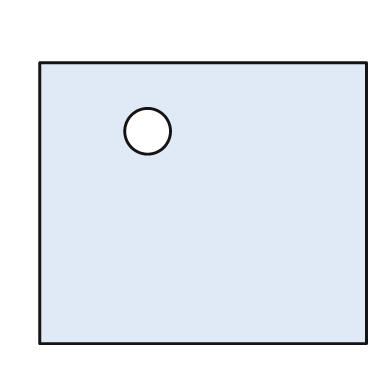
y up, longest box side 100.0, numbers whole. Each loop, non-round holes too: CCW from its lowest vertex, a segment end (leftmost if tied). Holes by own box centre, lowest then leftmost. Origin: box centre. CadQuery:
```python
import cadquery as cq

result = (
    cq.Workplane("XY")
    .moveTo(-50.0, -43.0)
    .lineTo(50.0, -43.0)
    .lineTo(50.0, 43.0)
    .lineTo(-50.0, 43.0)
    .close()
    .moveTo(-17.0, 22.0)
    .circle(7.0)
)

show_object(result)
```